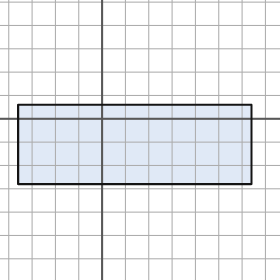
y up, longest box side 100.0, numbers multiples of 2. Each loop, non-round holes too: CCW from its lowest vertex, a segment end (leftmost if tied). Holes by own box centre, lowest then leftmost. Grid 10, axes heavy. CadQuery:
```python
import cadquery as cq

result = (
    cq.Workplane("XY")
    .moveTo(-36.0, -28.0)
    .lineTo(64.0, -28.0)
    .lineTo(64.0, 6.0)
    .lineTo(-36.0, 6.0)
    .close()
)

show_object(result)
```